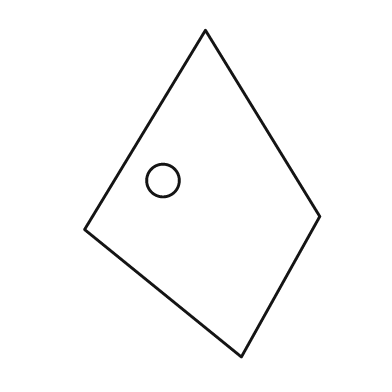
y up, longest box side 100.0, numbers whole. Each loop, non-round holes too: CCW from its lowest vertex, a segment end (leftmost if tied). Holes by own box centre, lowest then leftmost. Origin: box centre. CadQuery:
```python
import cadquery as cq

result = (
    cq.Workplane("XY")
    .moveTo(12.0, -50.0)
    .lineTo(36.0, -7.0)
    .lineTo(1.0, 50.0)
    .lineTo(-36.0, -11.0)
    .close()
    .moveTo(-12.0, 4.0)
    .circle(5.0)
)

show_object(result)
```